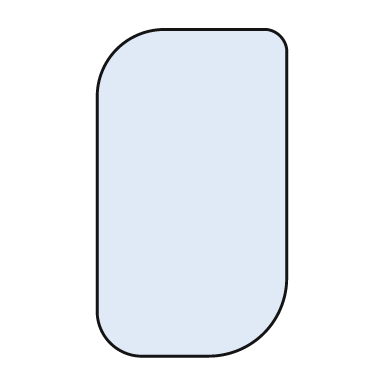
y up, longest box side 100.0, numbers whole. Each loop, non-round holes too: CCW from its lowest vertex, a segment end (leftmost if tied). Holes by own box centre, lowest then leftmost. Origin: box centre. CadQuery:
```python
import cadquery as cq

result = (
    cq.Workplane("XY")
    .moveTo(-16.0, -50.0)
    .lineTo(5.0, -50.0)
    .threePointArc((22.0, -43.0), (29.0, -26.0))
    .lineTo(29.0, 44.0)
    .threePointArc((27.0, 48.0), (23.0, 50.0))
    .lineTo(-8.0, 50.0)
    .threePointArc((-23.0, 44.0), (-29.0, 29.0))
    .lineTo(-29.0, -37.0)
    .threePointArc((-25.0, -46.0), (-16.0, -50.0))
    .close()
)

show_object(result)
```